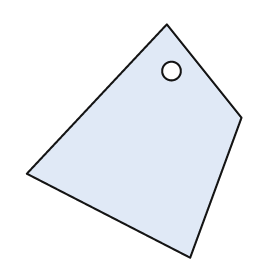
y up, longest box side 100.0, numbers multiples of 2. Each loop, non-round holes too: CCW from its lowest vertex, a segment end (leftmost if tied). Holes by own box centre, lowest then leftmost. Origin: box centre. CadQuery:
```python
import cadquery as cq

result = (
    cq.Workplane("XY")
    .moveTo(24.0, -50.0)
    .lineTo(46.0, 10.0)
    .lineTo(14.0, 50.0)
    .lineTo(-46.0, -14.0)
    .close()
    .moveTo(16.0, 30.0)
    .circle(4.0)
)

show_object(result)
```